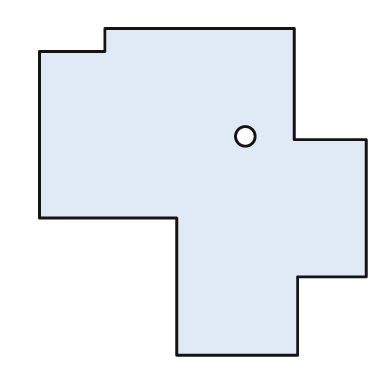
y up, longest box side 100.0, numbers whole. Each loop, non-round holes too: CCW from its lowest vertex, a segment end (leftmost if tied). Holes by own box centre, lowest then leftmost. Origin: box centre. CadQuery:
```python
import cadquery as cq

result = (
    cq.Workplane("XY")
    .moveTo(-8.0, -50.0)
    .lineTo(29.0, -50.0)
    .lineTo(29.0, -26.0)
    .lineTo(50.0, -26.0)
    .lineTo(50.0, 16.0)
    .lineTo(28.0, 16.0)
    .lineTo(28.0, 50.0)
    .lineTo(-30.0, 50.0)
    .lineTo(-30.0, 43.0)
    .lineTo(-50.0, 43.0)
    .lineTo(-50.0, -8.0)
    .lineTo(-8.0, -8.0)
    .close()
    .moveTo(13.0, 17.0)
    .circle(3.0)
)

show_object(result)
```